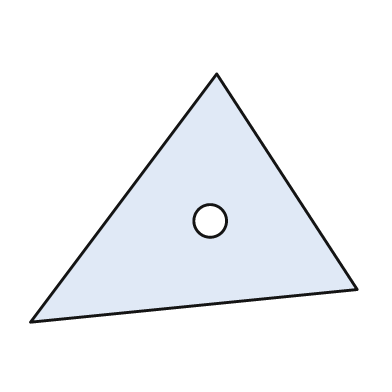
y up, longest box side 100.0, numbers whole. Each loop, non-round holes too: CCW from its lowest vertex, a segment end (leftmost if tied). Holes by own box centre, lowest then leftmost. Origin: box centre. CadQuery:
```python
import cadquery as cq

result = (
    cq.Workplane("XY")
    .moveTo(-50.0, -38.0)
    .lineTo(50.0, -28.0)
    .lineTo(7.0, 38.0)
    .close()
    .moveTo(5.0, -7.0)
    .circle(5.0)
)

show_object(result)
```